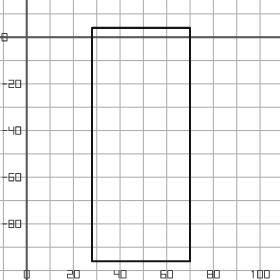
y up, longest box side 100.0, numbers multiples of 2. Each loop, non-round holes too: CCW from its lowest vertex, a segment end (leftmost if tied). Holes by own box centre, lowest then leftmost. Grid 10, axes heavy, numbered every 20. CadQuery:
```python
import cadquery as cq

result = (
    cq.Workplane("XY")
    .moveTo(28.0, -96.0)
    .lineTo(70.0, -96.0)
    .lineTo(70.0, 4.0)
    .lineTo(28.0, 4.0)
    .close()
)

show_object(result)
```